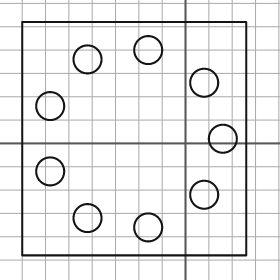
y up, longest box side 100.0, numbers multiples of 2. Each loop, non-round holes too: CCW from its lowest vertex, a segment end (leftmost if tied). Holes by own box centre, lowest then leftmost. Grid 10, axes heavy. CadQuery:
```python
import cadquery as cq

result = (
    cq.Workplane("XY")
    .moveTo(-70.0, -48.0)
    .lineTo(26.0, -48.0)
    .lineTo(26.0, 52.0)
    .lineTo(-70.0, 52.0)
    .close()
    .moveTo(-16.0, -36.0)
    .circle(6.0)
    .moveTo(-42.0, -32.0)
    .circle(6.0)
    .moveTo(8.0, -22.0)
    .circle(6.0)
    .moveTo(-58.0, -12.0)
    .circle(6.0)
    .moveTo(16.0, 2.0)
    .circle(6.0)
    .moveTo(-58.0, 16.0)
    .circle(6.0)
    .moveTo(8.0, 26.0)
    .circle(6.0)
    .moveTo(-42.0, 36.0)
    .circle(6.0)
    .moveTo(-16.0, 40.0)
    .circle(6.0)
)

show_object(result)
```